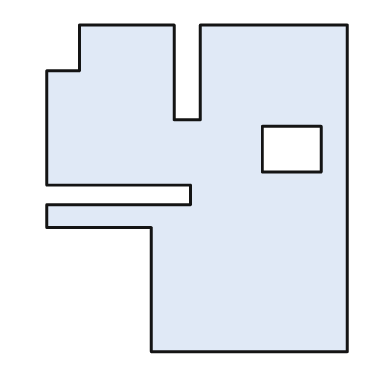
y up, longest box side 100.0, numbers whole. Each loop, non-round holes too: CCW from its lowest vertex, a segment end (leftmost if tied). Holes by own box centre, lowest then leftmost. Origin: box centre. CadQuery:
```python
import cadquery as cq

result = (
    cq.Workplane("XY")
    .moveTo(-14.0, -50.0)
    .lineTo(46.0, -50.0)
    .lineTo(46.0, 50.0)
    .lineTo(1.0, 50.0)
    .lineTo(1.0, 21.0)
    .lineTo(-7.0, 21.0)
    .lineTo(-7.0, 50.0)
    .lineTo(-36.0, 50.0)
    .lineTo(-36.0, 36.0)
    .lineTo(-46.0, 36.0)
    .lineTo(-46.0, 1.0)
    .lineTo(-2.0, 1.0)
    .lineTo(-2.0, -5.0)
    .lineTo(-46.0, -5.0)
    .lineTo(-46.0, -12.0)
    .lineTo(-14.0, -12.0)
    .close()
    .moveTo(20.0, 5.0)
    .lineTo(38.0, 5.0)
    .lineTo(38.0, 19.0)
    .lineTo(20.0, 19.0)
    .close()
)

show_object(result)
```